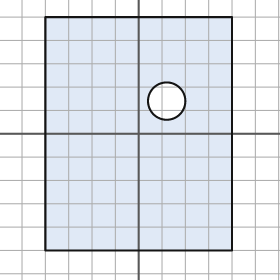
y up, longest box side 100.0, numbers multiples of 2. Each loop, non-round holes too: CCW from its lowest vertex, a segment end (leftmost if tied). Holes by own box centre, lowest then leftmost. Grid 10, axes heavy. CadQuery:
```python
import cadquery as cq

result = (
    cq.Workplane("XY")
    .moveTo(-40.0, -50.0)
    .lineTo(40.0, -50.0)
    .lineTo(40.0, 50.0)
    .lineTo(-40.0, 50.0)
    .close()
    .moveTo(12.0, 14.0)
    .circle(8.0)
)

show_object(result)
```